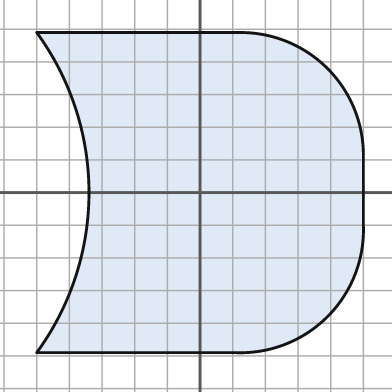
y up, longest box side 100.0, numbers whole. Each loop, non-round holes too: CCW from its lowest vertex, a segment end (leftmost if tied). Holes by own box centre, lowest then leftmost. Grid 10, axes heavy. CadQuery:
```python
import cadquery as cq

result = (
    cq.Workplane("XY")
    .moveTo(-50.0, -49.0)
    .lineTo(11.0, -49.0)
    .threePointArc((39.0, -38.0), (50.0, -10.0))
    .lineTo(50.0, 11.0)
    .threePointArc((39.0, 38.0), (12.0, 49.0))
    .lineTo(-50.0, 49.0)
    .threePointArc((-34.0, 0.0), (-50.0, -49.0))
    .close()
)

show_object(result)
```